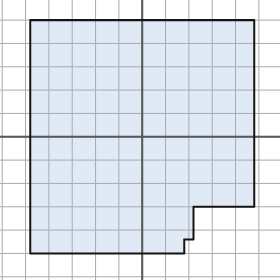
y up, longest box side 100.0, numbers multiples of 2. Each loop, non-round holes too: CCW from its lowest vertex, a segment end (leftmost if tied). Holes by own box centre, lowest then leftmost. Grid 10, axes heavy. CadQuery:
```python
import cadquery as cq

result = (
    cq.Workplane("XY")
    .moveTo(-48.0, -50.0)
    .lineTo(18.0, -50.0)
    .lineTo(18.0, -44.0)
    .lineTo(22.0, -44.0)
    .lineTo(22.0, -30.0)
    .lineTo(48.0, -30.0)
    .lineTo(48.0, 50.0)
    .lineTo(-48.0, 50.0)
    .close()
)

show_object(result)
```